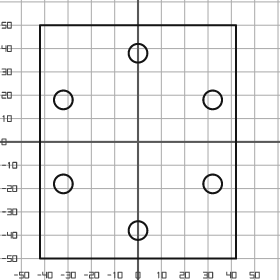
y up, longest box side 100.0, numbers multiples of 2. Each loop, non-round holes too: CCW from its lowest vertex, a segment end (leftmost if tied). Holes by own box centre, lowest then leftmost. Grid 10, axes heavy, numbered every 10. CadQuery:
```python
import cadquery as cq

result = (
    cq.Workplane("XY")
    .moveTo(-42.0, -50.0)
    .lineTo(42.0, -50.0)
    .lineTo(42.0, 50.0)
    .lineTo(-42.0, 50.0)
    .close()
    .moveTo(0.0, -38.0)
    .circle(4.0)
    .moveTo(-32.0, -18.0)
    .circle(4.0)
    .moveTo(32.0, -18.0)
    .circle(4.0)
    .moveTo(-32.0, 18.0)
    .circle(4.0)
    .moveTo(32.0, 18.0)
    .circle(4.0)
    .moveTo(0.0, 38.0)
    .circle(4.0)
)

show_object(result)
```